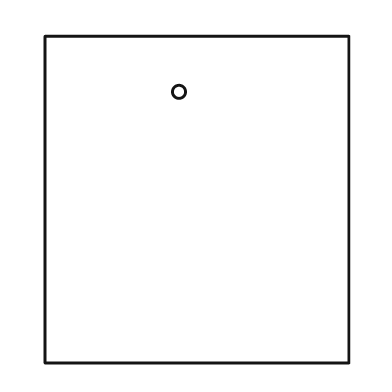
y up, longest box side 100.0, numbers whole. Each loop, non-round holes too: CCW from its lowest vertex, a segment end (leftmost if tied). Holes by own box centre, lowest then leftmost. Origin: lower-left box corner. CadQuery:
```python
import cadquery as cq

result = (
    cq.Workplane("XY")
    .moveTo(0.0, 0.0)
    .lineTo(93.0, 0.0)
    .lineTo(93.0, 100.0)
    .lineTo(0.0, 100.0)
    .close()
    .moveTo(41.0, 83.0)
    .circle(2.0)
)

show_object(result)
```